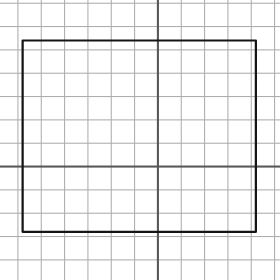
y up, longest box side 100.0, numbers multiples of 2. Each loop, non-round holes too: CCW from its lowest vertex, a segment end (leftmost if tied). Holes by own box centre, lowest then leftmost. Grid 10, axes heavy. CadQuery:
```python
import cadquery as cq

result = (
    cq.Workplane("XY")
    .moveTo(-58.0, -28.0)
    .lineTo(42.0, -28.0)
    .lineTo(42.0, 54.0)
    .lineTo(-58.0, 54.0)
    .close()
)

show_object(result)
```